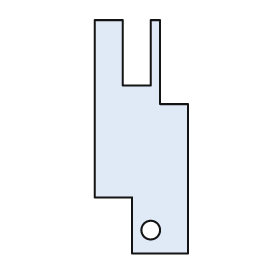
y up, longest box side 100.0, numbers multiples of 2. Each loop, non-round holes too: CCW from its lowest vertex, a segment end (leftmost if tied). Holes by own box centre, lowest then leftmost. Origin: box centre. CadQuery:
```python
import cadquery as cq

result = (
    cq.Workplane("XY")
    .moveTo(-4.0, -50.0)
    .lineTo(20.0, -50.0)
    .lineTo(20.0, 14.0)
    .lineTo(8.0, 14.0)
    .lineTo(8.0, 50.0)
    .lineTo(4.0, 50.0)
    .lineTo(4.0, 22.0)
    .lineTo(-8.0, 22.0)
    .lineTo(-8.0, 50.0)
    .lineTo(-20.0, 50.0)
    .lineTo(-20.0, -26.0)
    .lineTo(-4.0, -26.0)
    .close()
    .moveTo(4.0, -40.0)
    .circle(4.0)
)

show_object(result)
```